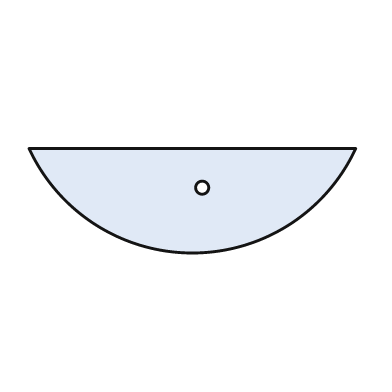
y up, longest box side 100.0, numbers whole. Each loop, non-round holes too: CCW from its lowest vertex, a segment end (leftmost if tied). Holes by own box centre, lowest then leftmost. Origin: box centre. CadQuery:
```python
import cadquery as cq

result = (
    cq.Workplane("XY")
    .moveTo(-50.0, 16.0)
    .threePointArc((0.0, -16.0), (50.0, 16.0))
    .close()
    .moveTo(3.0, 4.0)
    .circle(2.0)
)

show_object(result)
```